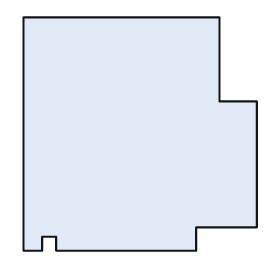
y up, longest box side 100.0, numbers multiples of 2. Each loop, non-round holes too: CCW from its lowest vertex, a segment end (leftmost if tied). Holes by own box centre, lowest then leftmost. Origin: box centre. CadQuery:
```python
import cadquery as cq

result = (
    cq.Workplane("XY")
    .moveTo(-50.0, -50.0)
    .lineTo(-42.0, -50.0)
    .lineTo(-42.0, -44.0)
    .lineTo(-36.0, -44.0)
    .lineTo(-36.0, -50.0)
    .lineTo(24.0, -50.0)
    .lineTo(24.0, -40.0)
    .lineTo(50.0, -40.0)
    .lineTo(50.0, 14.0)
    .lineTo(34.0, 14.0)
    .lineTo(34.0, 50.0)
    .lineTo(-50.0, 50.0)
    .close()
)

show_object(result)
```